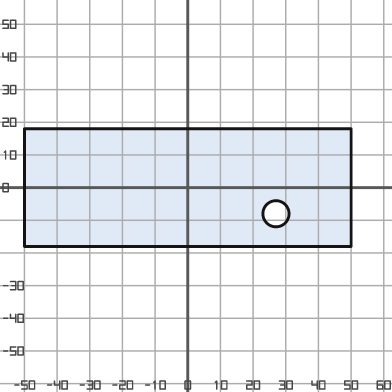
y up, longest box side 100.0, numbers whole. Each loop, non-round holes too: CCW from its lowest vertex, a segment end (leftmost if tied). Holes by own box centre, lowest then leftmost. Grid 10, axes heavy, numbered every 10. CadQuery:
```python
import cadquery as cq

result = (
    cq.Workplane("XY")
    .moveTo(-50.0, -18.0)
    .lineTo(50.0, -18.0)
    .lineTo(50.0, 18.0)
    .lineTo(-50.0, 18.0)
    .close()
    .moveTo(27.0, -8.0)
    .circle(4.0)
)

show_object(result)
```